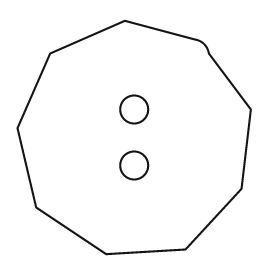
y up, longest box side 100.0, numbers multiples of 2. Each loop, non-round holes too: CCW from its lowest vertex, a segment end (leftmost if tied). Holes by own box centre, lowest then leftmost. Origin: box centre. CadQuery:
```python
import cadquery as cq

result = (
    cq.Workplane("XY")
    .moveTo(-12.0, -50.0)
    .lineTo(22.0, -48.0)
    .lineTo(46.0, -22.0)
    .lineTo(50.0, 12.0)
    .lineTo(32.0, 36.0)
    .threePointArc((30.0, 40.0), (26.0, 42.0))
    .lineTo(-4.0, 50.0)
    .lineTo(-36.0, 36.0)
    .lineTo(-50.0, 4.0)
    .lineTo(-42.0, -30.0)
    .close()
    .moveTo(0.0, -12.0)
    .circle(6.0)
    .moveTo(0.0, 12.0)
    .circle(6.0)
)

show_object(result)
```